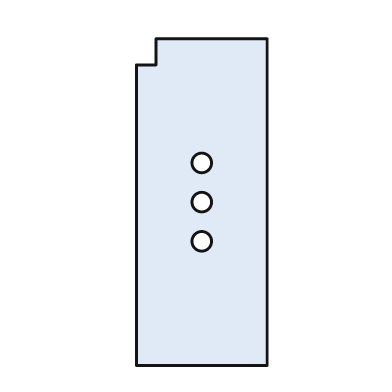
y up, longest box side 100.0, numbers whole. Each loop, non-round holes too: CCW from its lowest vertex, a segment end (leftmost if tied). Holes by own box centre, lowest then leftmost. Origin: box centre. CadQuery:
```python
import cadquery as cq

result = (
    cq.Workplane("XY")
    .moveTo(-20.0, -50.0)
    .lineTo(20.0, -50.0)
    .lineTo(20.0, 50.0)
    .lineTo(-14.0, 50.0)
    .lineTo(-14.0, 42.0)
    .lineTo(-20.0, 42.0)
    .close()
    .moveTo(0.0, -12.0)
    .circle(3.0)
    .moveTo(0.0, 0.0)
    .circle(3.0)
    .moveTo(0.0, 12.0)
    .circle(3.0)
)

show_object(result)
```